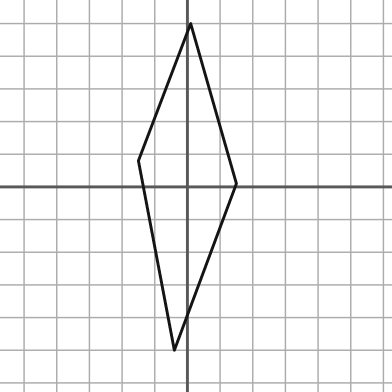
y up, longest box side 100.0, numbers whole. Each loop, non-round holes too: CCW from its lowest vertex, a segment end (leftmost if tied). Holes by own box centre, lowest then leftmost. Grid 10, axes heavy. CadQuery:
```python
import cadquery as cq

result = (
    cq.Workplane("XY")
    .moveTo(-4.0, -50.0)
    .lineTo(15.0, 1.0)
    .lineTo(1.0, 50.0)
    .lineTo(-15.0, 8.0)
    .close()
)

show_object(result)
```